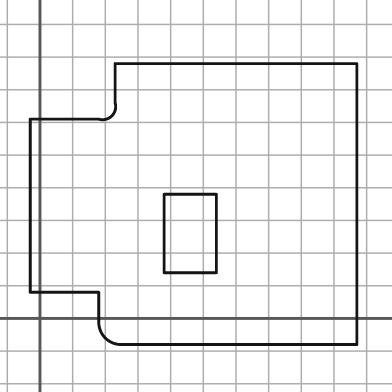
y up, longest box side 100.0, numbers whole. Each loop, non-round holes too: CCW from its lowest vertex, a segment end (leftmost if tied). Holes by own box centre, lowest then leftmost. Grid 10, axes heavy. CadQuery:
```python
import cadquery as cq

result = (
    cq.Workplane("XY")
    .moveTo(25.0, -8.0)
    .lineTo(97.0, -8.0)
    .lineTo(97.0, 78.0)
    .lineTo(23.0, 78.0)
    .lineTo(23.0, 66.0)
    .threePointArc((22.0, 62.0), (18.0, 61.0))
    .lineTo(-3.0, 61.0)
    .lineTo(-3.0, 8.0)
    .lineTo(18.0, 8.0)
    .lineTo(18.0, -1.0)
    .threePointArc((20.0, -6.0), (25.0, -8.0))
    .close()
    .moveTo(38.0, 14.0)
    .lineTo(54.0, 14.0)
    .lineTo(54.0, 38.0)
    .lineTo(38.0, 38.0)
    .close()
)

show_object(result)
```